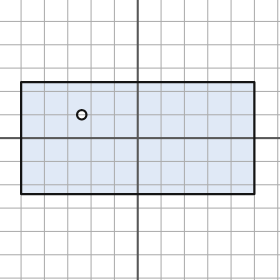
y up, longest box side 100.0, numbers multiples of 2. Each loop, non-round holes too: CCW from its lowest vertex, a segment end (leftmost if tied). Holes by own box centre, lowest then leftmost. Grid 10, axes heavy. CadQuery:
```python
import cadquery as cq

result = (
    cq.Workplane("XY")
    .moveTo(-50.0, -24.0)
    .lineTo(50.0, -24.0)
    .lineTo(50.0, 24.0)
    .lineTo(-50.0, 24.0)
    .close()
    .moveTo(-24.0, 10.0)
    .circle(2.0)
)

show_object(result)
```